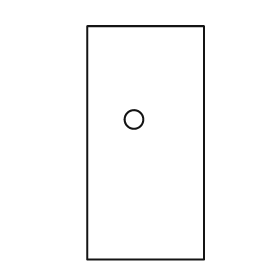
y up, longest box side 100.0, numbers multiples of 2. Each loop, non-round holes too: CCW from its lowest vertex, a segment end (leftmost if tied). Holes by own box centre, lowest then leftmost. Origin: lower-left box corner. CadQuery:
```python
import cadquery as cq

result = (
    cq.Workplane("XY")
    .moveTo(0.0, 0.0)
    .lineTo(50.0, 0.0)
    .lineTo(50.0, 100.0)
    .lineTo(0.0, 100.0)
    .close()
    .moveTo(20.0, 60.0)
    .circle(4.0)
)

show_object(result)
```